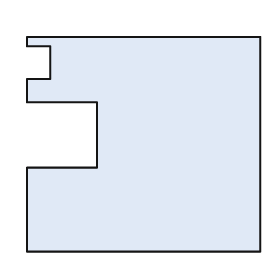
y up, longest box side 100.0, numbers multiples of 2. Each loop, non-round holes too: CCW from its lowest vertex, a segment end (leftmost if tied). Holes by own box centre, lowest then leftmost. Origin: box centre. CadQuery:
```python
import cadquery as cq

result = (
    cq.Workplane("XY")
    .moveTo(-50.0, -46.0)
    .lineTo(50.0, -46.0)
    .lineTo(50.0, 46.0)
    .lineTo(-50.0, 46.0)
    .lineTo(-50.0, 42.0)
    .lineTo(-40.0, 42.0)
    .lineTo(-40.0, 28.0)
    .lineTo(-50.0, 28.0)
    .lineTo(-50.0, 18.0)
    .lineTo(-20.0, 18.0)
    .lineTo(-20.0, -10.0)
    .lineTo(-50.0, -10.0)
    .close()
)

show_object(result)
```